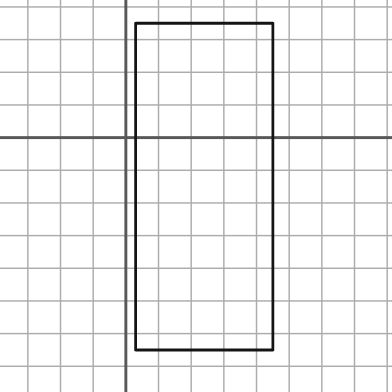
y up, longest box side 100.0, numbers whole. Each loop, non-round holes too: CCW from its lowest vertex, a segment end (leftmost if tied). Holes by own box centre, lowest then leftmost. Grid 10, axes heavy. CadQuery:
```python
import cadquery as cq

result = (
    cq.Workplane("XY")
    .moveTo(3.0, -65.0)
    .lineTo(45.0, -65.0)
    .lineTo(45.0, 35.0)
    .lineTo(3.0, 35.0)
    .close()
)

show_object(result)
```